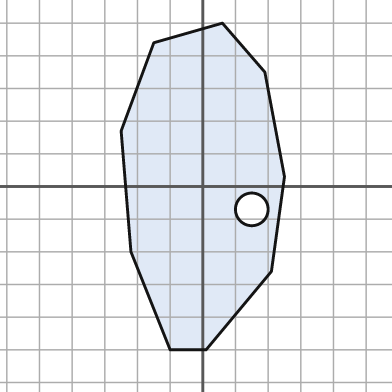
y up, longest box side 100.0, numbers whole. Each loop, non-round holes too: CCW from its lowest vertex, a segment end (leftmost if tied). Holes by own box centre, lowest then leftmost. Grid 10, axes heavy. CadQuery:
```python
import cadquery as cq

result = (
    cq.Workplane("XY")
    .moveTo(-10.0, -50.0)
    .lineTo(1.0, -50.0)
    .lineTo(21.0, -26.0)
    .lineTo(25.0, 3.0)
    .lineTo(19.0, 35.0)
    .lineTo(6.0, 50.0)
    .lineTo(-15.0, 44.0)
    .lineTo(-25.0, 17.0)
    .lineTo(-22.0, -20.0)
    .close()
    .moveTo(15.0, -7.0)
    .circle(5.0)
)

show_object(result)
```